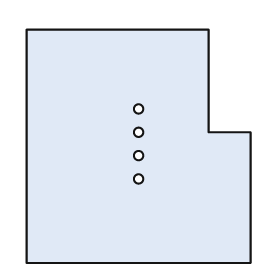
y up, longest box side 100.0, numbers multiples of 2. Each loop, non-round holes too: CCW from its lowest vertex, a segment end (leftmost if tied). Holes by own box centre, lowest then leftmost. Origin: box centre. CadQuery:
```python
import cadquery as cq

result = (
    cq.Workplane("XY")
    .moveTo(-48.0, -50.0)
    .lineTo(48.0, -50.0)
    .lineTo(48.0, 6.0)
    .lineTo(30.0, 6.0)
    .lineTo(30.0, 50.0)
    .lineTo(-48.0, 50.0)
    .close()
    .moveTo(0.0, -14.0)
    .circle(2.0)
    .moveTo(0.0, -4.0)
    .circle(2.0)
    .moveTo(0.0, 6.0)
    .circle(2.0)
    .moveTo(0.0, 16.0)
    .circle(2.0)
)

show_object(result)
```